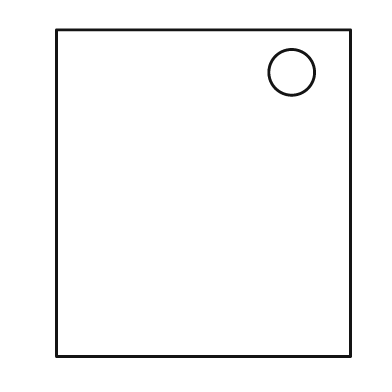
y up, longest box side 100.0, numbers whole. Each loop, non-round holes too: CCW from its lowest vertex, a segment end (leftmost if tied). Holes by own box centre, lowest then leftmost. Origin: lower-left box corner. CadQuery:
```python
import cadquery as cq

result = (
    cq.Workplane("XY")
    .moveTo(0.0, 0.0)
    .lineTo(90.0, 0.0)
    .lineTo(90.0, 100.0)
    .lineTo(0.0, 100.0)
    .close()
    .moveTo(72.0, 87.0)
    .circle(7.0)
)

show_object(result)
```